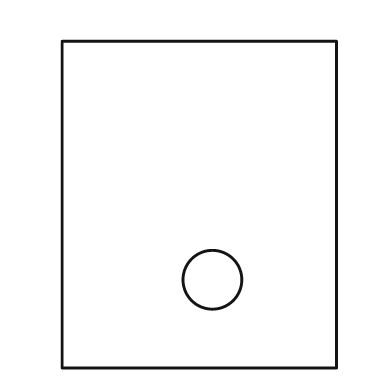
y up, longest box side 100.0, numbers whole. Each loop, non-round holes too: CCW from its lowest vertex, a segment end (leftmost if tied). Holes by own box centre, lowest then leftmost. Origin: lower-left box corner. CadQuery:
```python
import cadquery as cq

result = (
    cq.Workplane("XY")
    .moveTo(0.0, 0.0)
    .lineTo(84.0, 0.0)
    .lineTo(84.0, 100.0)
    .lineTo(0.0, 100.0)
    .close()
    .moveTo(46.0, 27.0)
    .circle(9.0)
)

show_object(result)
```